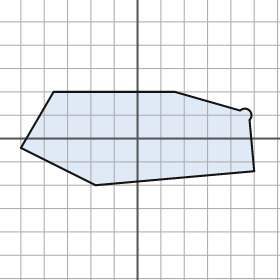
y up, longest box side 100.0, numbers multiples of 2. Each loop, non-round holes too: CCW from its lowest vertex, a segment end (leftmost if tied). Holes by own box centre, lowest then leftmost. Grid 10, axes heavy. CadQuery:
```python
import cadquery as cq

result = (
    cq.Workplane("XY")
    .moveTo(-18.0, -20.0)
    .lineTo(50.0, -14.0)
    .lineTo(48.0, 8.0)
    .threePointArc((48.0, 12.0), (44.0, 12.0))
    .lineTo(16.0, 20.0)
    .lineTo(-36.0, 20.0)
    .lineTo(-50.0, -4.0)
    .close()
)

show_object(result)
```